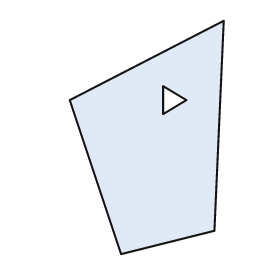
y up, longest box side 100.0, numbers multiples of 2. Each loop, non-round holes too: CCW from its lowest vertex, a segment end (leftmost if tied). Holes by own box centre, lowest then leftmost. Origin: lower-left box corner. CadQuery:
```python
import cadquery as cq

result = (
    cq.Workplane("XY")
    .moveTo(22.0, 0.0)
    .lineTo(62.0, 10.0)
    .lineTo(66.0, 100.0)
    .lineTo(0.0, 66.0)
    .close()
    .moveTo(40.0, 60.0)
    .lineTo(50.0, 66.0)
    .lineTo(40.0, 72.0)
    .close()
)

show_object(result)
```